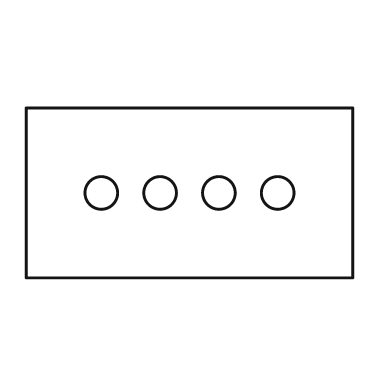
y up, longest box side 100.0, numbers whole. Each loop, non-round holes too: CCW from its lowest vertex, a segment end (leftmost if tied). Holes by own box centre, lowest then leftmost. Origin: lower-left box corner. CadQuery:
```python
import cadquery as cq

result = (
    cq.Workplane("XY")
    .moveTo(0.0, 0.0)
    .lineTo(100.0, 0.0)
    .lineTo(100.0, 52.0)
    .lineTo(0.0, 52.0)
    .close()
    .moveTo(23.0, 26.0)
    .circle(5.0)
    .moveTo(41.0, 26.0)
    .circle(5.0)
    .moveTo(59.0, 26.0)
    .circle(5.0)
    .moveTo(77.0, 26.0)
    .circle(5.0)
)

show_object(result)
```